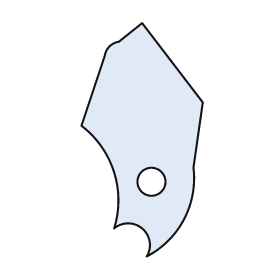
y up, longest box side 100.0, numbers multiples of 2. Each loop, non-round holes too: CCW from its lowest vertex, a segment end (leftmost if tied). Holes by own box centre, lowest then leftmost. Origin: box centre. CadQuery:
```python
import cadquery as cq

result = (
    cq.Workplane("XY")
    .moveTo(2.0, -50.0)
    .threePointArc((18.0, -34.0), (22.0, -12.0))
    .lineTo(26.0, 16.0)
    .lineTo(0.0, 50.0)
    .lineTo(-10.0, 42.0)
    .threePointArc((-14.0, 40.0), (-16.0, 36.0))
    .lineTo(-26.0, 6.0)
    .threePointArc((-12.0, -14.0), (-12.0, -38.0))
    .threePointArc((0.0, -38.0), (2.0, -50.0))
    .close()
    .moveTo(4.0, -18.0)
    .circle(6.0)
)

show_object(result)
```